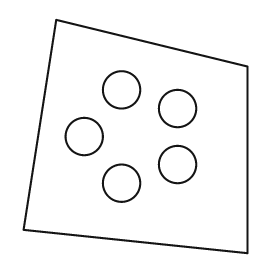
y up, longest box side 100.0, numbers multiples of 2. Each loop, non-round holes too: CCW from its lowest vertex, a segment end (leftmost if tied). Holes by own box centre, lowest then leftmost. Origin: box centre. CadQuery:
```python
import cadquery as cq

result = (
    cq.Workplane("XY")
    .moveTo(48.0, -50.0)
    .lineTo(48.0, 30.0)
    .lineTo(-34.0, 50.0)
    .lineTo(-48.0, -40.0)
    .close()
    .moveTo(-6.0, -20.0)
    .circle(8.0)
    .moveTo(18.0, -12.0)
    .circle(8.0)
    .moveTo(-22.0, 0.0)
    .circle(8.0)
    .moveTo(18.0, 12.0)
    .circle(8.0)
    .moveTo(-6.0, 20.0)
    .circle(8.0)
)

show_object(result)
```